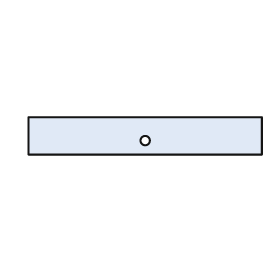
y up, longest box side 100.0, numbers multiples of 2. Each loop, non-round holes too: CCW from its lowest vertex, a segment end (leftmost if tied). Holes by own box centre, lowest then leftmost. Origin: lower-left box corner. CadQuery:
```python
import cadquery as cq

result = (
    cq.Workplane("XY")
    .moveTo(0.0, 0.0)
    .lineTo(100.0, 0.0)
    .lineTo(100.0, 16.0)
    .lineTo(0.0, 16.0)
    .close()
    .moveTo(50.0, 6.0)
    .circle(2.0)
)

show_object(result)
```